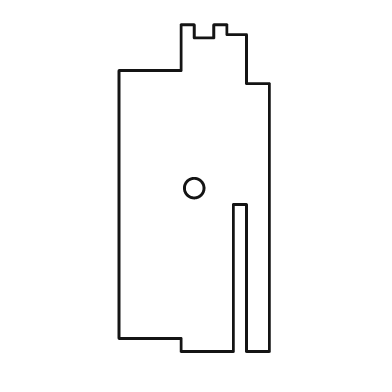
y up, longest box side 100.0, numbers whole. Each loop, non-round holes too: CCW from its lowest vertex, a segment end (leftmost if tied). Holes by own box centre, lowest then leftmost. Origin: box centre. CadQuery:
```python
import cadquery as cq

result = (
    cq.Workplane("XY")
    .moveTo(-4.0, -50.0)
    .lineTo(12.0, -50.0)
    .lineTo(12.0, -5.0)
    .lineTo(16.0, -5.0)
    .lineTo(16.0, -50.0)
    .lineTo(23.0, -50.0)
    .lineTo(23.0, 32.0)
    .lineTo(16.0, 32.0)
    .lineTo(16.0, 47.0)
    .lineTo(10.0, 47.0)
    .lineTo(10.0, 50.0)
    .lineTo(6.0, 50.0)
    .lineTo(6.0, 46.0)
    .lineTo(0.0, 46.0)
    .lineTo(0.0, 50.0)
    .lineTo(-4.0, 50.0)
    .lineTo(-4.0, 36.0)
    .lineTo(-23.0, 36.0)
    .lineTo(-23.0, -46.0)
    .lineTo(-4.0, -46.0)
    .close()
    .moveTo(0.0, 0.0)
    .circle(3.0)
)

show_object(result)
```